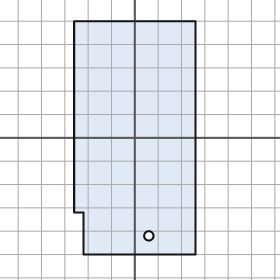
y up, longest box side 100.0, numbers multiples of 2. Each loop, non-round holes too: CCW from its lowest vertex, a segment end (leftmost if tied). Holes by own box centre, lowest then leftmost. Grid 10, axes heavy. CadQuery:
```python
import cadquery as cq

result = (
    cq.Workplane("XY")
    .moveTo(-22.0, -50.0)
    .lineTo(26.0, -50.0)
    .lineTo(26.0, 50.0)
    .lineTo(-26.0, 50.0)
    .lineTo(-26.0, -32.0)
    .lineTo(-22.0, -32.0)
    .close()
    .moveTo(6.0, -42.0)
    .circle(2.0)
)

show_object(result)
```